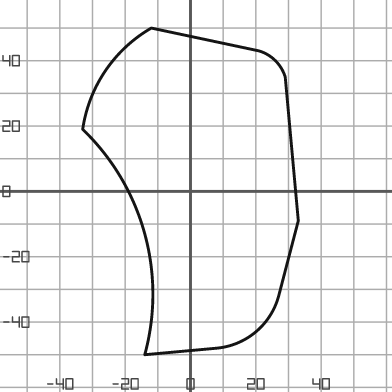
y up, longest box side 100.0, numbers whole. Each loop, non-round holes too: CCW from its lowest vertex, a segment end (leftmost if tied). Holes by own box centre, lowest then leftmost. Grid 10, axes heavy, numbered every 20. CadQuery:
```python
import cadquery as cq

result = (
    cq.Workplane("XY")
    .moveTo(-14.0, -50.0)
    .lineTo(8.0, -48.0)
    .threePointArc((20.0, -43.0), (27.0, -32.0))
    .lineTo(33.0, -9.0)
    .lineTo(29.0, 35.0)
    .threePointArc((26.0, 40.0), (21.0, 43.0))
    .lineTo(-12.0, 50.0)
    .threePointArc((-26.0, 37.0), (-33.0, 19.0))
    .threePointArc((-14.0, -13.0), (-14.0, -50.0))
    .close()
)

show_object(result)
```